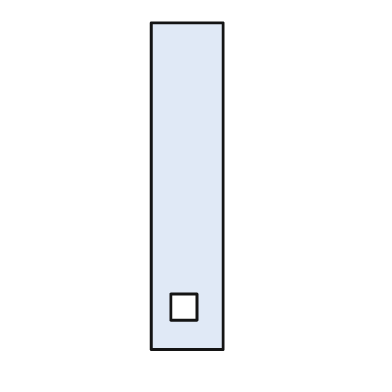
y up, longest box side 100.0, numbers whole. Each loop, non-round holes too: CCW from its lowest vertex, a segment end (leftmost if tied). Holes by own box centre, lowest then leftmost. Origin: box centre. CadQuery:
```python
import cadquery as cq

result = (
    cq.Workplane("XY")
    .moveTo(-11.0, -50.0)
    .lineTo(11.0, -50.0)
    .lineTo(11.0, 50.0)
    .lineTo(-11.0, 50.0)
    .close()
    .moveTo(-5.0, -41.0)
    .lineTo(3.0, -41.0)
    .lineTo(3.0, -33.0)
    .lineTo(-5.0, -33.0)
    .close()
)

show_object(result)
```